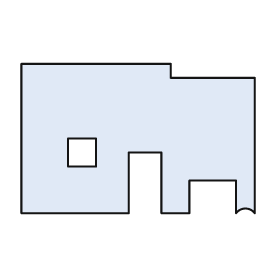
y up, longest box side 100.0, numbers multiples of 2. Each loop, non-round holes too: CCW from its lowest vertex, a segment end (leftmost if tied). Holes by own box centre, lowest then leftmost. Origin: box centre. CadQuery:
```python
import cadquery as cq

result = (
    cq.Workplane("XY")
    .moveTo(-50.0, -32.0)
    .lineTo(-4.0, -32.0)
    .lineTo(-4.0, -6.0)
    .lineTo(10.0, -6.0)
    .lineTo(10.0, -32.0)
    .lineTo(22.0, -32.0)
    .lineTo(22.0, -18.0)
    .lineTo(42.0, -18.0)
    .lineTo(42.0, -32.0)
    .threePointArc((46.0, -30.0), (50.0, -32.0))
    .lineTo(50.0, 26.0)
    .lineTo(14.0, 26.0)
    .lineTo(14.0, 32.0)
    .lineTo(-50.0, 32.0)
    .close()
    .moveTo(-30.0, -12.0)
    .lineTo(-18.0, -12.0)
    .lineTo(-18.0, 0.0)
    .lineTo(-30.0, 0.0)
    .close()
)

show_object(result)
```